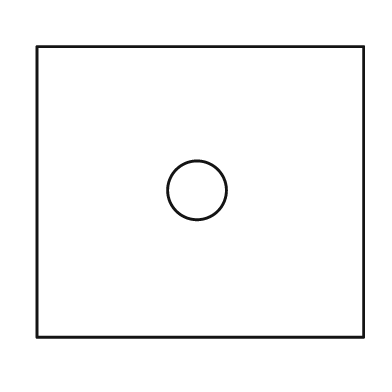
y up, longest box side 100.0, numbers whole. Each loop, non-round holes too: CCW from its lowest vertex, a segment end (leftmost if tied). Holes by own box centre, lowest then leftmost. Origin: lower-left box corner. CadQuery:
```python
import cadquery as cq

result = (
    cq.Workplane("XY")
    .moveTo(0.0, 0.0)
    .lineTo(100.0, 0.0)
    .lineTo(100.0, 89.0)
    .lineTo(0.0, 89.0)
    .close()
    .moveTo(49.0, 45.0)
    .circle(9.0)
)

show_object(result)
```